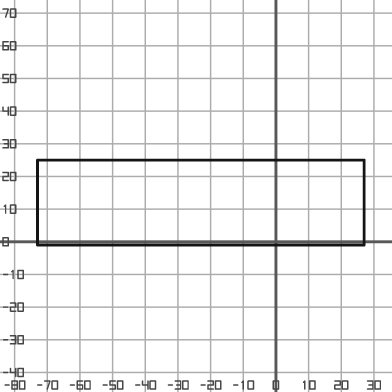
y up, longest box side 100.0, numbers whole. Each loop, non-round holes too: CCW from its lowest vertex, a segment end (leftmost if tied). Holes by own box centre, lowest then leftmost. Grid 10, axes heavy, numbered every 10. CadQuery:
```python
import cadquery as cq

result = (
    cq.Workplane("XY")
    .moveTo(-73.0, -1.0)
    .lineTo(27.0, -1.0)
    .lineTo(27.0, 25.0)
    .lineTo(-73.0, 25.0)
    .close()
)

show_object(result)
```